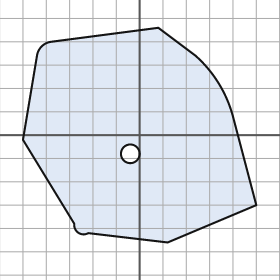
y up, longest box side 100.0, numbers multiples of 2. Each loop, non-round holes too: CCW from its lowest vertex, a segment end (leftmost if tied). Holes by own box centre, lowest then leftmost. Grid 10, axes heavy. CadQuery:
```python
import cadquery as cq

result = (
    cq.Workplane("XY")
    .moveTo(12.0, -46.0)
    .lineTo(50.0, -30.0)
    .lineTo(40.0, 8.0)
    .threePointArc((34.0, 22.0), (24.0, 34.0))
    .lineTo(8.0, 46.0)
    .lineTo(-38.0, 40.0)
    .threePointArc((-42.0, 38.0), (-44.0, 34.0))
    .lineTo(-50.0, -2.0)
    .lineTo(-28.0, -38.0)
    .threePointArc((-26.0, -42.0), (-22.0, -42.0))
    .close()
    .moveTo(-4.0, -8.0)
    .circle(4.0)
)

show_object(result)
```